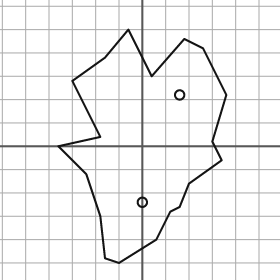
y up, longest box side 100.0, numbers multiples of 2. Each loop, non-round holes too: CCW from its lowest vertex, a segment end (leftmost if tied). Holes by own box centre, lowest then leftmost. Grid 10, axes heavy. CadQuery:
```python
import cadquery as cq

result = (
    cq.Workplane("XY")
    .moveTo(-10.0, -50.0)
    .lineTo(6.0, -40.0)
    .lineTo(12.0, -28.0)
    .lineTo(16.0, -26.0)
    .lineTo(20.0, -16.0)
    .lineTo(34.0, -6.0)
    .lineTo(30.0, 2.0)
    .lineTo(36.0, 22.0)
    .lineTo(26.0, 42.0)
    .lineTo(18.0, 46.0)
    .lineTo(4.0, 30.0)
    .lineTo(-6.0, 50.0)
    .lineTo(-16.0, 38.0)
    .lineTo(-30.0, 28.0)
    .lineTo(-18.0, 4.0)
    .lineTo(-36.0, 0.0)
    .lineTo(-24.0, -12.0)
    .lineTo(-18.0, -30.0)
    .lineTo(-16.0, -48.0)
    .close()
    .moveTo(0.0, -24.0)
    .circle(2.0)
    .moveTo(16.0, 22.0)
    .circle(2.0)
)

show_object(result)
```